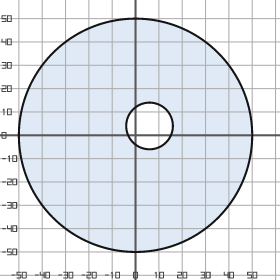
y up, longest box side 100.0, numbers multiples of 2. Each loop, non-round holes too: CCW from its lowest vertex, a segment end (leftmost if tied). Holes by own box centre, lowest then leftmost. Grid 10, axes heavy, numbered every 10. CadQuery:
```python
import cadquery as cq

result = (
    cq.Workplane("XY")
    .moveTo(0.0, 0.0)
    .circle(50.0)
    .moveTo(6.0, 4.0)
    .circle(10.0)
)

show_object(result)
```